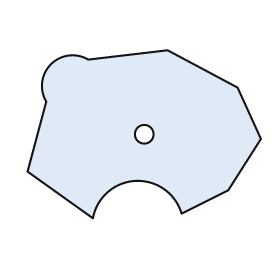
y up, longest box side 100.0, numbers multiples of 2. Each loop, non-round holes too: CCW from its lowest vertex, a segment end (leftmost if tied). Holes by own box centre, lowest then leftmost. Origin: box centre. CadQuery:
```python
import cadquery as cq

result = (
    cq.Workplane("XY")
    .moveTo(-22.0, -36.0)
    .threePointArc((-4.0, -20.0), (16.0, -34.0))
    .lineTo(36.0, -24.0)
    .lineTo(50.0, -2.0)
    .lineTo(40.0, 20.0)
    .lineTo(10.0, 36.0)
    .lineTo(-24.0, 32.0)
    .threePointArc((-40.0, 30.0), (-42.0, 14.0))
    .lineTo(-50.0, -16.0)
    .close()
    .moveTo(0.0, 0.0)
    .circle(4.0)
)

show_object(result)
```